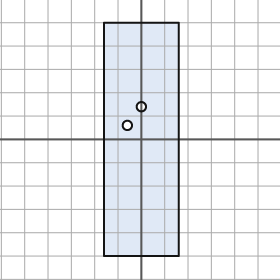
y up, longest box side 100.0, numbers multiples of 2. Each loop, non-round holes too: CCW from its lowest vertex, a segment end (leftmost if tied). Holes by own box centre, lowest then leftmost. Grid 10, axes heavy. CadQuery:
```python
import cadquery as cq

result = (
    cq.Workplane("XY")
    .moveTo(-16.0, -50.0)
    .lineTo(16.0, -50.0)
    .lineTo(16.0, 50.0)
    .lineTo(-16.0, 50.0)
    .close()
    .moveTo(-6.0, 6.0)
    .circle(2.0)
    .moveTo(0.0, 14.0)
    .circle(2.0)
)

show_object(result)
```